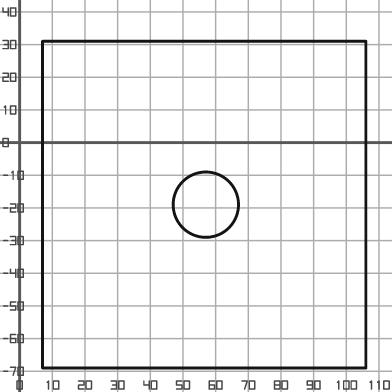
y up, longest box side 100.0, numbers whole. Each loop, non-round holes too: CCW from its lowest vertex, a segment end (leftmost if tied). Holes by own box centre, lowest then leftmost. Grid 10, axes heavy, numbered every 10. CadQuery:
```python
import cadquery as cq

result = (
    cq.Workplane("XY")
    .moveTo(7.0, -69.0)
    .lineTo(106.0, -69.0)
    .lineTo(106.0, 31.0)
    .lineTo(7.0, 31.0)
    .close()
    .moveTo(57.0, -19.0)
    .circle(10.0)
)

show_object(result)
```